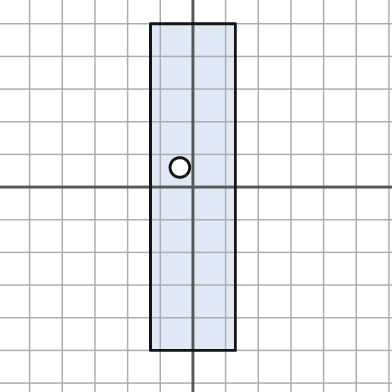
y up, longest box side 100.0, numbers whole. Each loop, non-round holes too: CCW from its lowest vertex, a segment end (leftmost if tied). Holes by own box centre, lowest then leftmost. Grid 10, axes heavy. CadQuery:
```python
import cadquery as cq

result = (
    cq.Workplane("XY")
    .moveTo(-13.0, -50.0)
    .lineTo(13.0, -50.0)
    .lineTo(13.0, 50.0)
    .lineTo(-13.0, 50.0)
    .close()
    .moveTo(-4.0, 6.0)
    .circle(3.0)
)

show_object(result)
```